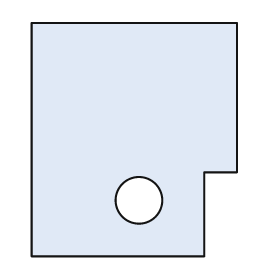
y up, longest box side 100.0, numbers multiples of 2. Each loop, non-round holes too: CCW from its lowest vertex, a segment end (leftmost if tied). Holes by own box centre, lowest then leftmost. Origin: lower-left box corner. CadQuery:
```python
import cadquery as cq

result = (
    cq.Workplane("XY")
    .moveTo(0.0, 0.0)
    .lineTo(74.0, 0.0)
    .lineTo(74.0, 36.0)
    .lineTo(88.0, 36.0)
    .lineTo(88.0, 100.0)
    .lineTo(0.0, 100.0)
    .close()
    .moveTo(46.0, 24.0)
    .circle(10.0)
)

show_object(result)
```